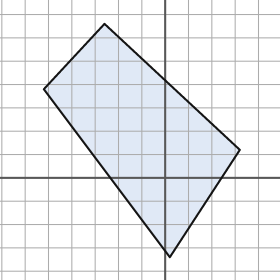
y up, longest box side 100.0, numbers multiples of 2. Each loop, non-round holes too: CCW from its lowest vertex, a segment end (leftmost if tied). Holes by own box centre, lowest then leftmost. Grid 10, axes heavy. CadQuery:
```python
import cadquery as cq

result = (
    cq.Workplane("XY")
    .moveTo(2.0, -34.0)
    .lineTo(32.0, 12.0)
    .lineTo(-26.0, 66.0)
    .lineTo(-52.0, 38.0)
    .close()
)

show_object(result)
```